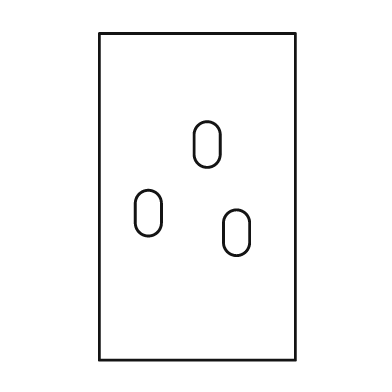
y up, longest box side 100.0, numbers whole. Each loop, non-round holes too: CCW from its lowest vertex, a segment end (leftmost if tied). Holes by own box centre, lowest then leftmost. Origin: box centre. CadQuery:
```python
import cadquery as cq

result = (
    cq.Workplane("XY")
    .moveTo(-30.0, -50.0)
    .lineTo(30.0, -50.0)
    .lineTo(30.0, 50.0)
    .lineTo(-30.0, 50.0)
    .close()
    .moveTo(8.0, -14.0)
    .threePointArc((12.0, -18.0), (16.0, -14.0))
    .lineTo(16.0, -8.0)
    .threePointArc((12.0, -4.0), (8.0, -8.0))
    .close()
    .moveTo(-19.0, -8.0)
    .threePointArc((-15.0, -12.0), (-11.0, -8.0))
    .lineTo(-11.0, -2.0)
    .threePointArc((-15.0, 2.0), (-19.0, -2.0))
    .close()
    .moveTo(-1.0, 13.0)
    .threePointArc((3.0, 9.0), (7.0, 13.0))
    .lineTo(7.0, 19.0)
    .threePointArc((3.0, 23.0), (-1.0, 19.0))
    .close()
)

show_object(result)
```